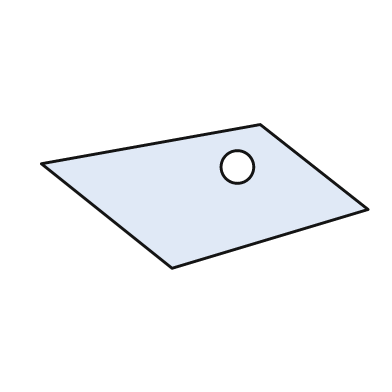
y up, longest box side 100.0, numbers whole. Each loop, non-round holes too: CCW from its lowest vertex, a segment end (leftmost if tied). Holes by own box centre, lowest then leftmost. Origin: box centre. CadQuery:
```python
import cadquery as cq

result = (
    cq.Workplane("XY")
    .moveTo(-10.0, -22.0)
    .lineTo(50.0, -4.0)
    .lineTo(17.0, 22.0)
    .lineTo(-50.0, 10.0)
    .close()
    .moveTo(10.0, 9.0)
    .circle(5.0)
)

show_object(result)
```